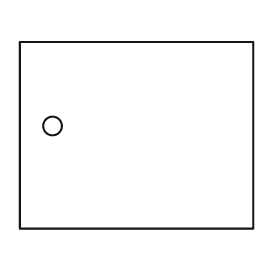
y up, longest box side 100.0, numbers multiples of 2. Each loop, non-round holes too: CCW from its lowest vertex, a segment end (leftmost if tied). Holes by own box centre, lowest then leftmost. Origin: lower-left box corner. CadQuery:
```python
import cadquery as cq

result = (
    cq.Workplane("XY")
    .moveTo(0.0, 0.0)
    .lineTo(100.0, 0.0)
    .lineTo(100.0, 80.0)
    .lineTo(0.0, 80.0)
    .close()
    .moveTo(14.0, 44.0)
    .circle(4.0)
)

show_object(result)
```